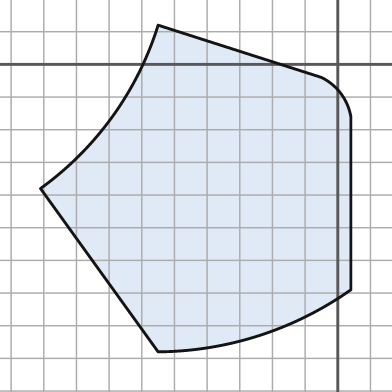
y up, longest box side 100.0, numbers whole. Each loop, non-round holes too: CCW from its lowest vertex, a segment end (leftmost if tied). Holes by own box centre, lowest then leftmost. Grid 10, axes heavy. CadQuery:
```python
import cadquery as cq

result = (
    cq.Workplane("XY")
    .moveTo(-55.0, -88.0)
    .threePointArc((-24.0, -83.0), (4.0, -69.0))
    .lineTo(4.0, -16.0)
    .threePointArc((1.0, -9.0), (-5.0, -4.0))
    .lineTo(-55.0, 12.0)
    .threePointArc((-69.0, -16.0), (-91.0, -38.0))
    .close()
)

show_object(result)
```